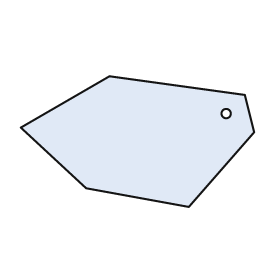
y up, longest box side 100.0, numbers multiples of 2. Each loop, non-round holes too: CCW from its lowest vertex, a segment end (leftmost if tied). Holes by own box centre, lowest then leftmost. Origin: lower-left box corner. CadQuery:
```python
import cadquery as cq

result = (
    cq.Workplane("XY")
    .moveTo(72.0, 0.0)
    .lineTo(100.0, 32.0)
    .lineTo(96.0, 48.0)
    .lineTo(38.0, 56.0)
    .lineTo(0.0, 34.0)
    .lineTo(28.0, 8.0)
    .close()
    .moveTo(88.0, 40.0)
    .circle(2.0)
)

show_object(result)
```